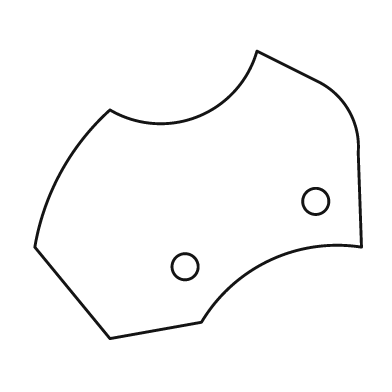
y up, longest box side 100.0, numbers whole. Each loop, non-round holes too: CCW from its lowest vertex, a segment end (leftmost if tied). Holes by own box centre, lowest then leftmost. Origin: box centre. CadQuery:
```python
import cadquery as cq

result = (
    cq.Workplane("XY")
    .moveTo(-27.0, -44.0)
    .lineTo(1.0, -39.0)
    .threePointArc((22.0, -20.0), (50.0, -16.0))
    .lineTo(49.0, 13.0)
    .threePointArc((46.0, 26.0), (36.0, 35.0))
    .lineTo(18.0, 44.0)
    .threePointArc((0.0, 24.0), (-27.0, 26.0))
    .threePointArc((-42.0, 7.0), (-50.0, -16.0))
    .close()
    .moveTo(-4.0, -22.0)
    .circle(4.0)
    .moveTo(36.0, -2.0)
    .circle(4.0)
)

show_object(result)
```